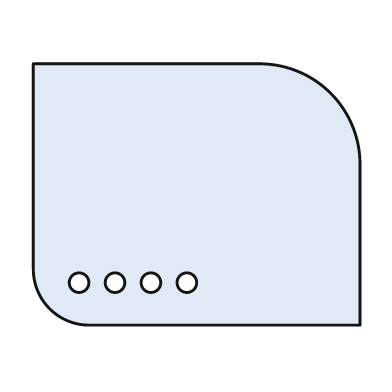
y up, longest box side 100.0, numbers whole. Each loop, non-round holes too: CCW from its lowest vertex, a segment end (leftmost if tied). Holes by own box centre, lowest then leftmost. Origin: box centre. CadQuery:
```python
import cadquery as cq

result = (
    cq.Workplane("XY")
    .moveTo(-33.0, -40.0)
    .lineTo(50.0, -40.0)
    .lineTo(50.0, 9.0)
    .threePointArc((41.0, 31.0), (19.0, 40.0))
    .lineTo(-50.0, 40.0)
    .lineTo(-50.0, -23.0)
    .threePointArc((-45.0, -35.0), (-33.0, -40.0))
    .close()
    .moveTo(-36.0, -27.0)
    .circle(3.0)
    .moveTo(-25.0, -27.0)
    .circle(3.0)
    .moveTo(-14.0, -27.0)
    .circle(3.0)
    .moveTo(-3.0, -27.0)
    .circle(3.0)
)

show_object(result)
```